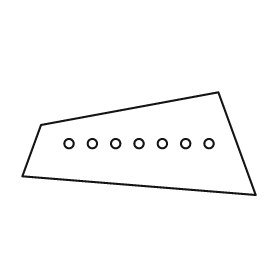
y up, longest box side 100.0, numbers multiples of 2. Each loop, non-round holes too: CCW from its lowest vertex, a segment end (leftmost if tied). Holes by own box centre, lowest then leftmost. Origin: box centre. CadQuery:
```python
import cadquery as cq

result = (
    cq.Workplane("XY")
    .moveTo(50.0, -22.0)
    .lineTo(34.0, 22.0)
    .lineTo(-42.0, 8.0)
    .lineTo(-50.0, -14.0)
    .close()
    .moveTo(-30.0, 0.0)
    .circle(2.0)
    .moveTo(-20.0, 0.0)
    .circle(2.0)
    .moveTo(-10.0, 0.0)
    .circle(2.0)
    .moveTo(0.0, 0.0)
    .circle(2.0)
    .moveTo(10.0, 0.0)
    .circle(2.0)
    .moveTo(20.0, 0.0)
    .circle(2.0)
    .moveTo(30.0, 0.0)
    .circle(2.0)
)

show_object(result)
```